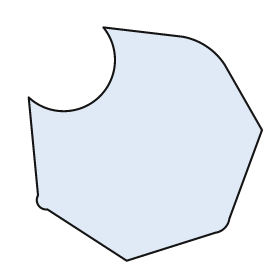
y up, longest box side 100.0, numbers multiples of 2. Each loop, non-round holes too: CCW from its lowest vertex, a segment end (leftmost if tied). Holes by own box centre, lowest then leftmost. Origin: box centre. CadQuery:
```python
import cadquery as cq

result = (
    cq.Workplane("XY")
    .moveTo(-8.0, -50.0)
    .lineTo(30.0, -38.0)
    .threePointArc((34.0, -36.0), (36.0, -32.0))
    .lineTo(50.0, 6.0)
    .lineTo(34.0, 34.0)
    .threePointArc((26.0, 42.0), (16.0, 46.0))
    .lineTo(-18.0, 50.0)
    .threePointArc((-20.0, 20.0), (-50.0, 20.0))
    .lineTo(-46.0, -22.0)
    .threePointArc((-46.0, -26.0), (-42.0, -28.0))
    .close()
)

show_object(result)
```